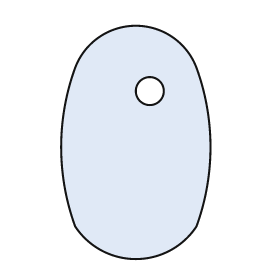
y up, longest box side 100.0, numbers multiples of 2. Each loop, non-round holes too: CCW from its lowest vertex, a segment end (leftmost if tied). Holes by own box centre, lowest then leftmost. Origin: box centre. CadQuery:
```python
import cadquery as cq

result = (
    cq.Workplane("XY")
    .moveTo(-26.0, -36.0)
    .threePointArc((0.0, -50.0), (26.0, -36.0))
    .threePointArc((32.0, -2.0), (26.0, 32.0))
    .threePointArc((0.0, 50.0), (-26.0, 32.0))
    .threePointArc((-32.0, -2.0), (-26.0, -36.0))
    .close()
    .moveTo(6.0, 22.0)
    .circle(6.0)
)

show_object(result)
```